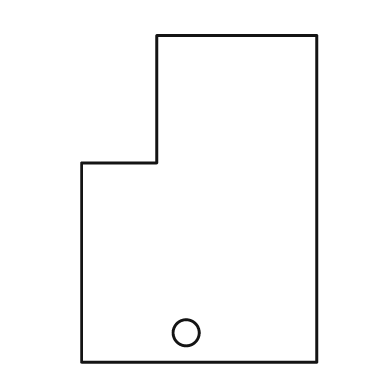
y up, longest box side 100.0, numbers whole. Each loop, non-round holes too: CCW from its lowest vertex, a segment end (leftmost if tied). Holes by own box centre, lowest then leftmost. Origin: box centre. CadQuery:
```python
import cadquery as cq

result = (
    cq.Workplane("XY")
    .moveTo(-36.0, -50.0)
    .lineTo(36.0, -50.0)
    .lineTo(36.0, 50.0)
    .lineTo(-13.0, 50.0)
    .lineTo(-13.0, 11.0)
    .lineTo(-36.0, 11.0)
    .close()
    .moveTo(-4.0, -41.0)
    .circle(4.0)
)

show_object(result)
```